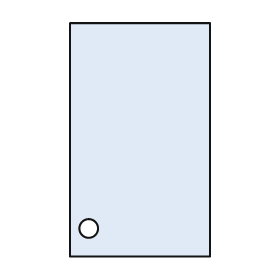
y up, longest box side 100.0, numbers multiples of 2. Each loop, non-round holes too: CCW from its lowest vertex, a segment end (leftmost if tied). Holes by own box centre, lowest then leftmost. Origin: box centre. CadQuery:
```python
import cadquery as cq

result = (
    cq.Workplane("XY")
    .moveTo(-30.0, -50.0)
    .lineTo(30.0, -50.0)
    .lineTo(30.0, 50.0)
    .lineTo(-30.0, 50.0)
    .close()
    .moveTo(-22.0, -38.0)
    .circle(4.0)
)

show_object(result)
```